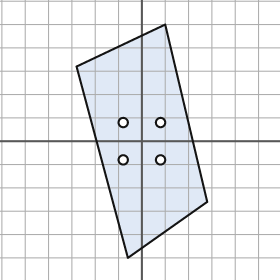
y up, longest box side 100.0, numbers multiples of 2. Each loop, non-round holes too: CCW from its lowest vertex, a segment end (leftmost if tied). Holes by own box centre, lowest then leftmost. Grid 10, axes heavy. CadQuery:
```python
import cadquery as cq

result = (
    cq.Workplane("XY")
    .moveTo(-6.0, -50.0)
    .lineTo(28.0, -26.0)
    .lineTo(10.0, 50.0)
    .lineTo(-28.0, 32.0)
    .close()
    .moveTo(-8.0, -8.0)
    .circle(2.0)
    .moveTo(8.0, -8.0)
    .circle(2.0)
    .moveTo(-8.0, 8.0)
    .circle(2.0)
    .moveTo(8.0, 8.0)
    .circle(2.0)
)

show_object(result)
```